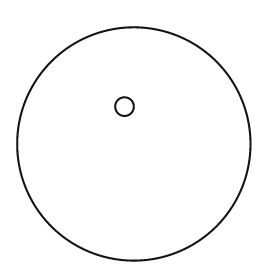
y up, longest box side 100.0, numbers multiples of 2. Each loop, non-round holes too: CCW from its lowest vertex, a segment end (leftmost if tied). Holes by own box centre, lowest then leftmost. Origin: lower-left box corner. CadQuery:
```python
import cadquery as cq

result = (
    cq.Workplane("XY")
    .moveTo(50.0, 50.0)
    .circle(50.0)
    .moveTo(46.0, 66.0)
    .circle(4.0)
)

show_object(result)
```